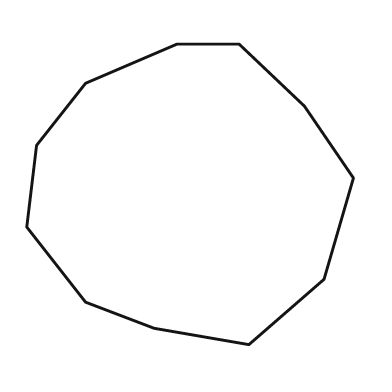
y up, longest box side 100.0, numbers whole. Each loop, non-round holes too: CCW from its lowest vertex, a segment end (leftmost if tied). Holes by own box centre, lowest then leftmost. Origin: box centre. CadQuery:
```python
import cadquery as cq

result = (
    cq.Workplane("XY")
    .moveTo(18.0, -46.0)
    .lineTo(41.0, -26.0)
    .lineTo(50.0, 5.0)
    .lineTo(35.0, 27.0)
    .lineTo(15.0, 46.0)
    .lineTo(-4.0, 46.0)
    .lineTo(-32.0, 34.0)
    .lineTo(-47.0, 15.0)
    .lineTo(-50.0, -10.0)
    .lineTo(-32.0, -33.0)
    .lineTo(-11.0, -41.0)
    .close()
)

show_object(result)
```